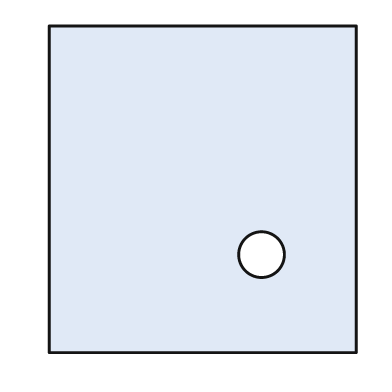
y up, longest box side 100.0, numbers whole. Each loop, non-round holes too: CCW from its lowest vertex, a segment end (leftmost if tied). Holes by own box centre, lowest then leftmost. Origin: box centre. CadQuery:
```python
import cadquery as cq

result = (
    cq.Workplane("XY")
    .moveTo(-47.0, -50.0)
    .lineTo(47.0, -50.0)
    .lineTo(47.0, 50.0)
    .lineTo(-47.0, 50.0)
    .close()
    .moveTo(18.0, -20.0)
    .circle(7.0)
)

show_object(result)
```